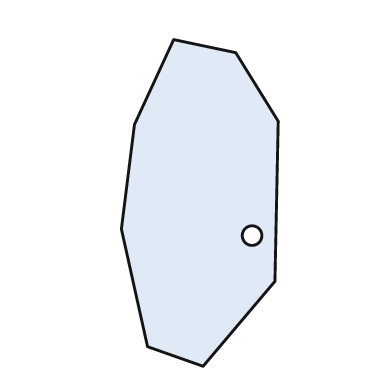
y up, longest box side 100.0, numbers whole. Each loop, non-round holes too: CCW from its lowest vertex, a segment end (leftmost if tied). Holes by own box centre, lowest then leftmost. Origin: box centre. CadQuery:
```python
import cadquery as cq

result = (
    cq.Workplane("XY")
    .moveTo(1.0, -50.0)
    .lineTo(23.0, -24.0)
    .lineTo(24.0, 25.0)
    .lineTo(11.0, 46.0)
    .lineTo(-8.0, 50.0)
    .lineTo(-20.0, 24.0)
    .lineTo(-24.0, -8.0)
    .lineTo(-16.0, -44.0)
    .close()
    .moveTo(16.0, -10.0)
    .circle(3.0)
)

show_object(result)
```